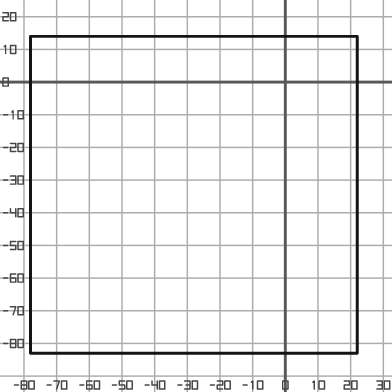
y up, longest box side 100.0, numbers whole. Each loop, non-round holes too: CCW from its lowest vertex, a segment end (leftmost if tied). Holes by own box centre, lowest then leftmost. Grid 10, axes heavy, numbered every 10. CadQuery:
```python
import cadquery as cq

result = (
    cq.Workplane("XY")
    .moveTo(-78.0, -83.0)
    .lineTo(22.0, -83.0)
    .lineTo(22.0, 14.0)
    .lineTo(-78.0, 14.0)
    .close()
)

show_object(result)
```